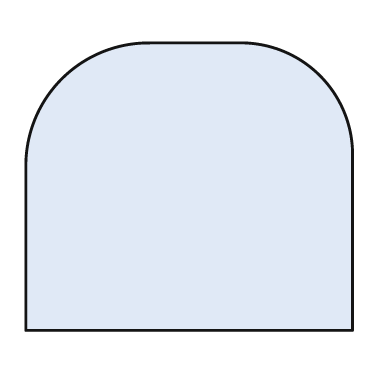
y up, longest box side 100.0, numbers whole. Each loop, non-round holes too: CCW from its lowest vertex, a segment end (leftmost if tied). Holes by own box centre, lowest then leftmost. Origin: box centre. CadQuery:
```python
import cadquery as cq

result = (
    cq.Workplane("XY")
    .moveTo(-50.0, -44.0)
    .lineTo(50.0, -44.0)
    .lineTo(50.0, 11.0)
    .threePointArc((40.0, 34.0), (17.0, 44.0))
    .lineTo(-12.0, 44.0)
    .threePointArc((-39.0, 33.0), (-50.0, 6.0))
    .close()
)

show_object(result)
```